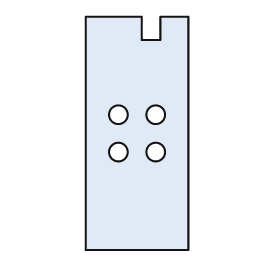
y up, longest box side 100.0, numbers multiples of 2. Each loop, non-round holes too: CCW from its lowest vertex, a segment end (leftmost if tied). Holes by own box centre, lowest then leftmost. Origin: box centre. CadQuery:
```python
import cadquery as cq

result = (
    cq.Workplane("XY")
    .moveTo(-22.0, -50.0)
    .lineTo(22.0, -50.0)
    .lineTo(22.0, 50.0)
    .lineTo(10.0, 50.0)
    .lineTo(10.0, 40.0)
    .lineTo(2.0, 40.0)
    .lineTo(2.0, 50.0)
    .lineTo(-22.0, 50.0)
    .close()
    .moveTo(-8.0, -8.0)
    .circle(4.0)
    .moveTo(8.0, -8.0)
    .circle(4.0)
    .moveTo(-8.0, 8.0)
    .circle(4.0)
    .moveTo(8.0, 8.0)
    .circle(4.0)
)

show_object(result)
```